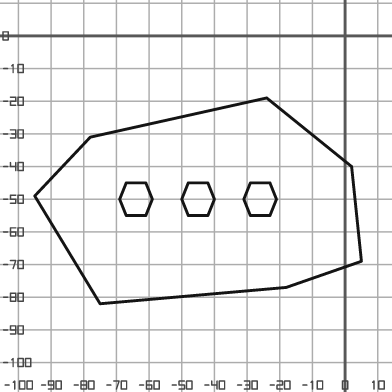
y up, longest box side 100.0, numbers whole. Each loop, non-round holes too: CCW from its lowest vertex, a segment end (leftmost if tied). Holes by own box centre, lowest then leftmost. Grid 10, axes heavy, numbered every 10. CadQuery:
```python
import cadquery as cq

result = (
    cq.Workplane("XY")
    .moveTo(-75.0, -82.0)
    .lineTo(-18.0, -77.0)
    .lineTo(5.0, -69.0)
    .lineTo(2.0, -40.0)
    .lineTo(-24.0, -19.0)
    .lineTo(-78.0, -31.0)
    .lineTo(-95.0, -49.0)
    .close()
    .moveTo(-67.0, -55.0)
    .lineTo(-61.0, -55.0)
    .lineTo(-59.0, -50.0)
    .lineTo(-61.0, -45.0)
    .lineTo(-67.0, -45.0)
    .lineTo(-69.0, -50.0)
    .close()
    .moveTo(-48.0, -55.0)
    .lineTo(-42.0, -55.0)
    .lineTo(-40.0, -50.0)
    .lineTo(-42.0, -45.0)
    .lineTo(-48.0, -45.0)
    .lineTo(-50.0, -50.0)
    .close()
    .moveTo(-29.0, -55.0)
    .lineTo(-23.0, -55.0)
    .lineTo(-21.0, -50.0)
    .lineTo(-23.0, -45.0)
    .lineTo(-29.0, -45.0)
    .lineTo(-31.0, -50.0)
    .close()
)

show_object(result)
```